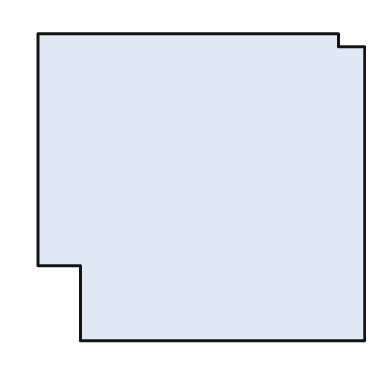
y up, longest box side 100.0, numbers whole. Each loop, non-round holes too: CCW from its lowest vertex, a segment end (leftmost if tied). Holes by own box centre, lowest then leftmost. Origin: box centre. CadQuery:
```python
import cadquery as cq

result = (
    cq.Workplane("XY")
    .moveTo(-37.0, -47.0)
    .lineTo(50.0, -47.0)
    .lineTo(50.0, 43.0)
    .lineTo(42.0, 43.0)
    .lineTo(42.0, 47.0)
    .lineTo(-50.0, 47.0)
    .lineTo(-50.0, -24.0)
    .lineTo(-37.0, -24.0)
    .close()
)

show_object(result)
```